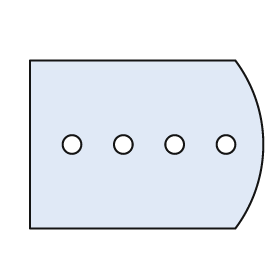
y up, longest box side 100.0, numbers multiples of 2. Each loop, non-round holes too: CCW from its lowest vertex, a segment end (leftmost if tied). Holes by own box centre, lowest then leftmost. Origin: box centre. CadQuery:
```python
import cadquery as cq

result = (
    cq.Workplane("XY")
    .moveTo(-50.0, -36.0)
    .lineTo(38.0, -36.0)
    .threePointArc((50.0, 0.0), (38.0, 36.0))
    .lineTo(-50.0, 36.0)
    .close()
    .moveTo(-32.0, 0.0)
    .circle(4.0)
    .moveTo(-10.0, 0.0)
    .circle(4.0)
    .moveTo(12.0, 0.0)
    .circle(4.0)
    .moveTo(34.0, 0.0)
    .circle(4.0)
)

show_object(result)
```